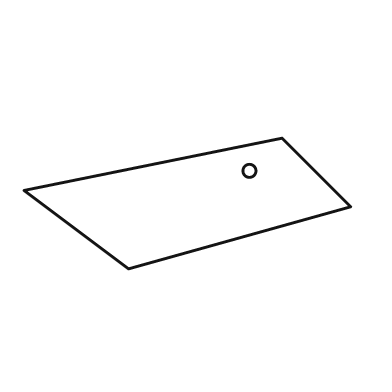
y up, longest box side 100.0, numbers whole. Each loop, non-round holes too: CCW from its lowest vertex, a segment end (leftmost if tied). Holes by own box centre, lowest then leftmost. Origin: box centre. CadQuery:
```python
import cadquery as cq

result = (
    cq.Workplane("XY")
    .moveTo(-18.0, -20.0)
    .lineTo(50.0, -1.0)
    .lineTo(29.0, 20.0)
    .lineTo(-50.0, 4.0)
    .close()
    .moveTo(19.0, 10.0)
    .circle(2.0)
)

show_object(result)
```